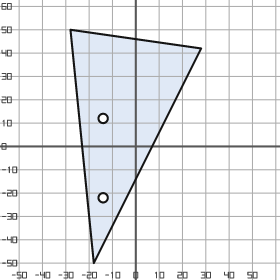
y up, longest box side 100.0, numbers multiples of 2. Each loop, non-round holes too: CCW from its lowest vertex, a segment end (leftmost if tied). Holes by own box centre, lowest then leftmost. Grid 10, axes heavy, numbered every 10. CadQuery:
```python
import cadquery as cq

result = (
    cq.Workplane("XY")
    .moveTo(-18.0, -50.0)
    .lineTo(28.0, 42.0)
    .lineTo(-28.0, 50.0)
    .close()
    .moveTo(-14.0, -22.0)
    .circle(2.0)
    .moveTo(-14.0, 12.0)
    .circle(2.0)
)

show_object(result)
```